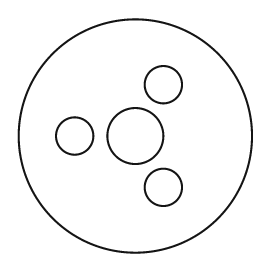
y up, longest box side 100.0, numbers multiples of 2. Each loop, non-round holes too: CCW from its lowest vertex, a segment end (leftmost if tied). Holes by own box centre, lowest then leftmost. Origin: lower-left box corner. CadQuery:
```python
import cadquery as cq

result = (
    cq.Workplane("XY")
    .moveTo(50.0, 50.0)
    .circle(50.0)
    .moveTo(62.0, 28.0)
    .circle(8.0)
    .moveTo(24.0, 50.0)
    .circle(8.0)
    .moveTo(50.0, 50.0)
    .circle(12.0)
    .moveTo(62.0, 72.0)
    .circle(8.0)
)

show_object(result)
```